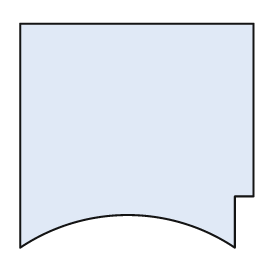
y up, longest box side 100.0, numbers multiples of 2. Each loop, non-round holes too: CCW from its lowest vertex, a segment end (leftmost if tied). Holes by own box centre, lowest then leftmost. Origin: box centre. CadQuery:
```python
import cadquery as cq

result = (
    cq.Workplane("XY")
    .moveTo(-50.0, -48.0)
    .threePointArc((-4.0, -34.0), (42.0, -48.0))
    .lineTo(42.0, -26.0)
    .lineTo(50.0, -26.0)
    .lineTo(50.0, 48.0)
    .lineTo(-50.0, 48.0)
    .close()
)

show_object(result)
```